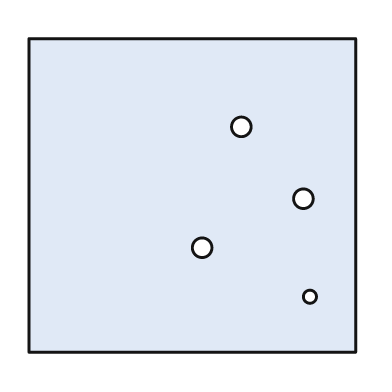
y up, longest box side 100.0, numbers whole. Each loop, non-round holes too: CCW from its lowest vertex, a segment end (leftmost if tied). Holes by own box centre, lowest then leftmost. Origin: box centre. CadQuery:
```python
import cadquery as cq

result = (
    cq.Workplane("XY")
    .moveTo(-50.0, -48.0)
    .lineTo(50.0, -48.0)
    .lineTo(50.0, 48.0)
    .lineTo(-50.0, 48.0)
    .close()
    .moveTo(36.0, -31.0)
    .circle(2.0)
    .moveTo(3.0, -16.0)
    .circle(3.0)
    .moveTo(34.0, -1.0)
    .circle(3.0)
    .moveTo(15.0, 21.0)
    .circle(3.0)
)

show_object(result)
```